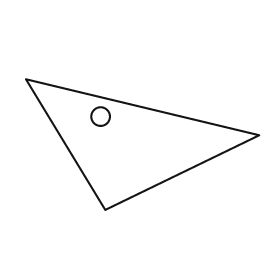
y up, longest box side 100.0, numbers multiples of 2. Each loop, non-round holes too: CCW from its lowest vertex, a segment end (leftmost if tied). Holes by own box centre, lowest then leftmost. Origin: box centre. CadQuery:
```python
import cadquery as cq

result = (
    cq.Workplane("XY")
    .moveTo(-16.0, -28.0)
    .lineTo(50.0, 4.0)
    .lineTo(-50.0, 28.0)
    .close()
    .moveTo(-18.0, 12.0)
    .circle(4.0)
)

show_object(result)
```